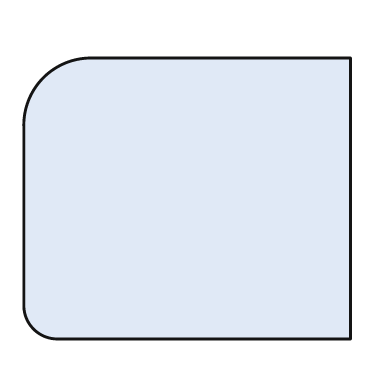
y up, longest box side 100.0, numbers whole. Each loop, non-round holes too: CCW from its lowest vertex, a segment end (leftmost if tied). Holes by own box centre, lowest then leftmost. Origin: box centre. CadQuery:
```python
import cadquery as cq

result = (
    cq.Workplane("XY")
    .moveTo(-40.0, -43.0)
    .lineTo(50.0, -43.0)
    .lineTo(50.0, 43.0)
    .lineTo(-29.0, 43.0)
    .threePointArc((-44.0, 37.0), (-50.0, 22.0))
    .lineTo(-50.0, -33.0)
    .threePointArc((-47.0, -40.0), (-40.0, -43.0))
    .close()
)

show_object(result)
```